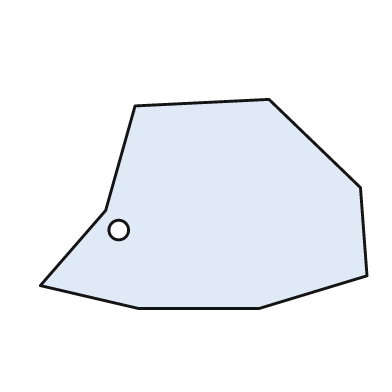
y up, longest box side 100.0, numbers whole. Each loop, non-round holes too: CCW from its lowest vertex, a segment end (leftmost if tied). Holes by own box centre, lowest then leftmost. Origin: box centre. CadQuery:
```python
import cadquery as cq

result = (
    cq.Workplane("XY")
    .moveTo(-20.0, -32.0)
    .lineTo(17.0, -32.0)
    .lineTo(50.0, -22.0)
    .lineTo(48.0, 5.0)
    .lineTo(20.0, 32.0)
    .lineTo(-21.0, 30.0)
    .lineTo(-30.0, -2.0)
    .lineTo(-50.0, -25.0)
    .close()
    .moveTo(-26.0, -8.0)
    .circle(3.0)
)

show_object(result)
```